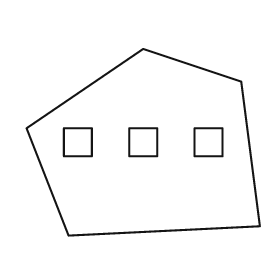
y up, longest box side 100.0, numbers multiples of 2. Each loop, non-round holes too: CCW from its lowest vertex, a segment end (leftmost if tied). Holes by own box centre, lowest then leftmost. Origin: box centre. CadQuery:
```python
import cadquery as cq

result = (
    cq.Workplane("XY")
    .moveTo(-32.0, -40.0)
    .lineTo(50.0, -36.0)
    .lineTo(42.0, 26.0)
    .lineTo(0.0, 40.0)
    .lineTo(-50.0, 6.0)
    .close()
    .moveTo(-34.0, -6.0)
    .lineTo(-22.0, -6.0)
    .lineTo(-22.0, 6.0)
    .lineTo(-34.0, 6.0)
    .close()
    .moveTo(-6.0, -6.0)
    .lineTo(6.0, -6.0)
    .lineTo(6.0, 6.0)
    .lineTo(-6.0, 6.0)
    .close()
    .moveTo(22.0, -6.0)
    .lineTo(34.0, -6.0)
    .lineTo(34.0, 6.0)
    .lineTo(22.0, 6.0)
    .close()
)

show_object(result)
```